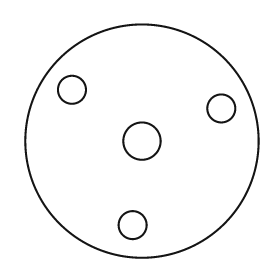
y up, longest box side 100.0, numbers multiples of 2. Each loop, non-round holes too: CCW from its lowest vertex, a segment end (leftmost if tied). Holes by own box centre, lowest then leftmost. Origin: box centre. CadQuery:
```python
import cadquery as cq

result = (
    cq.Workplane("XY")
    .moveTo(0.0, 0.0)
    .circle(50.0)
    .moveTo(-4.0, -36.0)
    .circle(6.0)
    .moveTo(0.0, 0.0)
    .circle(8.0)
    .moveTo(34.0, 14.0)
    .circle(6.0)
    .moveTo(-30.0, 22.0)
    .circle(6.0)
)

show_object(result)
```